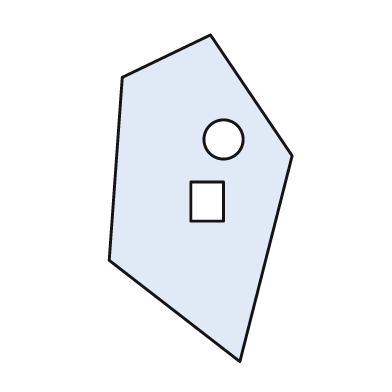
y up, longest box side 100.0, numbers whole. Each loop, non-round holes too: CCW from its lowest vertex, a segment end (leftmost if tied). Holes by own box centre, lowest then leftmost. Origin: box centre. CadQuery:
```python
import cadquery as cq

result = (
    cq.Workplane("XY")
    .moveTo(12.0, -50.0)
    .lineTo(28.0, 13.0)
    .lineTo(3.0, 50.0)
    .lineTo(-24.0, 37.0)
    .lineTo(-28.0, -19.0)
    .close()
    .moveTo(-3.0, -7.0)
    .lineTo(7.0, -7.0)
    .lineTo(7.0, 5.0)
    .lineTo(-3.0, 5.0)
    .close()
    .moveTo(7.0, 18.0)
    .circle(6.0)
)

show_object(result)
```